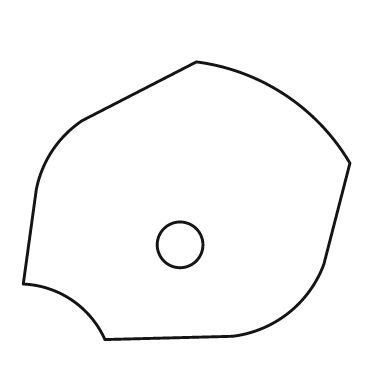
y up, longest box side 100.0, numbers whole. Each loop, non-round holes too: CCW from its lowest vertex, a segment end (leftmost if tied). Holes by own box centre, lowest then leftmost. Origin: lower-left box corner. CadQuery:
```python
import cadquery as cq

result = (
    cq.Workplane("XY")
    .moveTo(25.0, 0.0)
    .lineTo(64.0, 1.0)
    .threePointArc((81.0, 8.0), (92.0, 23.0))
    .lineTo(100.0, 54.0)
    .threePointArc((80.0, 75.0), (53.0, 85.0))
    .lineTo(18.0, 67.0)
    .threePointArc((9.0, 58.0), (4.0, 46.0))
    .lineTo(0.0, 17.0)
    .threePointArc((15.0, 12.0), (25.0, 0.0))
    .close()
    .moveTo(48.0, 29.0)
    .circle(7.0)
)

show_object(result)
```